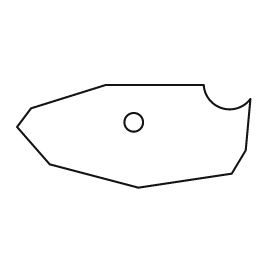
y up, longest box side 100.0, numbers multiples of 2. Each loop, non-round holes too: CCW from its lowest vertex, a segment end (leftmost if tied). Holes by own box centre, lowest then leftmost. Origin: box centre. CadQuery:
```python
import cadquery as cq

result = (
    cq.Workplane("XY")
    .moveTo(2.0, -22.0)
    .lineTo(42.0, -16.0)
    .lineTo(48.0, -6.0)
    .lineTo(50.0, 16.0)
    .threePointArc((38.0, 12.0), (30.0, 22.0))
    .lineTo(-12.0, 22.0)
    .lineTo(-44.0, 12.0)
    .lineTo(-50.0, 4.0)
    .lineTo(-36.0, -12.0)
    .close()
    .moveTo(0.0, 6.0)
    .circle(4.0)
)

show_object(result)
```